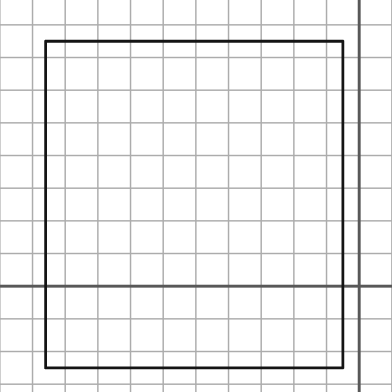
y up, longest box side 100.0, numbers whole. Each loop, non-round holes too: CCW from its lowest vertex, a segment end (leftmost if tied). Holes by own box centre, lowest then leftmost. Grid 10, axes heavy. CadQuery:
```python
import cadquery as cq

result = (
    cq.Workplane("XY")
    .moveTo(-96.0, -25.0)
    .lineTo(-5.0, -25.0)
    .lineTo(-5.0, 75.0)
    .lineTo(-96.0, 75.0)
    .close()
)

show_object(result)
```